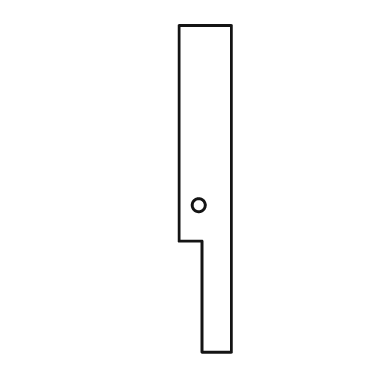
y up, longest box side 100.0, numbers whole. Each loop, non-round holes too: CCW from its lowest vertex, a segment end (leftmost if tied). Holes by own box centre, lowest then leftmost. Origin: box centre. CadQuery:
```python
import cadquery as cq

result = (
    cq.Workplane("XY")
    .moveTo(-1.0, -50.0)
    .lineTo(8.0, -50.0)
    .lineTo(8.0, 50.0)
    .lineTo(-8.0, 50.0)
    .lineTo(-8.0, -16.0)
    .lineTo(-1.0, -16.0)
    .close()
    .moveTo(-2.0, -5.0)
    .circle(2.0)
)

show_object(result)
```